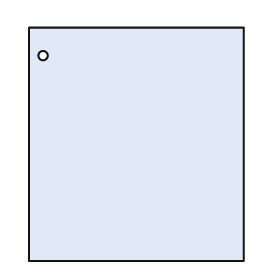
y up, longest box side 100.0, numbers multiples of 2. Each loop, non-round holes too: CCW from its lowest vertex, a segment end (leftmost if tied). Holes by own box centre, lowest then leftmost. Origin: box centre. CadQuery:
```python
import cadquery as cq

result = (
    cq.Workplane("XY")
    .moveTo(-46.0, -50.0)
    .lineTo(46.0, -50.0)
    .lineTo(46.0, 50.0)
    .lineTo(-46.0, 50.0)
    .close()
    .moveTo(-40.0, 38.0)
    .circle(2.0)
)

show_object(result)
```